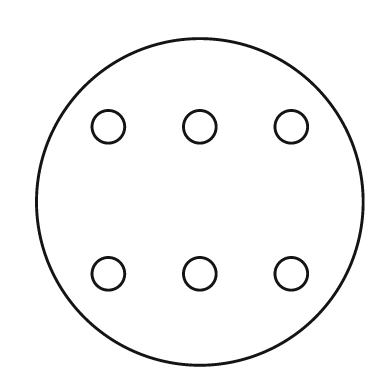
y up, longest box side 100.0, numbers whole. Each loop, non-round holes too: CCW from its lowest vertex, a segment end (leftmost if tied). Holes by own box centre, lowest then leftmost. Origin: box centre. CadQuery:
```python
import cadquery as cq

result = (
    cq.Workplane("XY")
    .moveTo(0.0, 0.0)
    .circle(50.0)
    .moveTo(-28.0, -22.0)
    .circle(5.0)
    .moveTo(0.0, -22.0)
    .circle(5.0)
    .moveTo(28.0, -22.0)
    .circle(5.0)
    .moveTo(-28.0, 23.0)
    .circle(5.0)
    .moveTo(0.0, 23.0)
    .circle(5.0)
    .moveTo(28.0, 23.0)
    .circle(5.0)
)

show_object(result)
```